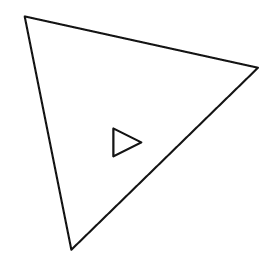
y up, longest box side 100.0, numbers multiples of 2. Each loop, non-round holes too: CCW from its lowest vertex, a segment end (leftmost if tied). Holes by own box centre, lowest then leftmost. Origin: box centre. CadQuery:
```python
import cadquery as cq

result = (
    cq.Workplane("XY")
    .moveTo(-30.0, -50.0)
    .lineTo(50.0, 28.0)
    .lineTo(-50.0, 50.0)
    .close()
    .moveTo(-12.0, -10.0)
    .lineTo(0.0, -4.0)
    .lineTo(-12.0, 2.0)
    .close()
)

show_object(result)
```